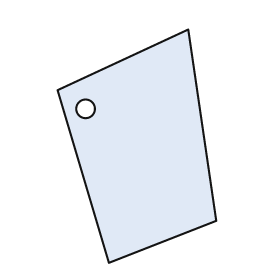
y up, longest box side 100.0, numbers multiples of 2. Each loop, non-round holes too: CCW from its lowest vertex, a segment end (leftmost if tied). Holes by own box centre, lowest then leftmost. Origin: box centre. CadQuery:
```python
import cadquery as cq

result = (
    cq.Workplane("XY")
    .moveTo(-12.0, -50.0)
    .lineTo(34.0, -32.0)
    .lineTo(22.0, 50.0)
    .lineTo(-34.0, 24.0)
    .close()
    .moveTo(-22.0, 16.0)
    .circle(4.0)
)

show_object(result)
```